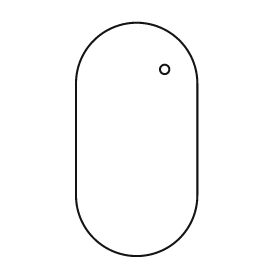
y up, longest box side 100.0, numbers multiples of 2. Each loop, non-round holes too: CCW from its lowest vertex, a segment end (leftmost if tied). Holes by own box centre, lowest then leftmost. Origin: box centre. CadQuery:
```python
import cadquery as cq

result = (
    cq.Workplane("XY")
    .moveTo(-26.0, -24.0)
    .threePointArc((0.0, -50.0), (26.0, -24.0))
    .lineTo(26.0, 24.0)
    .threePointArc((0.0, 50.0), (-26.0, 24.0))
    .close()
    .moveTo(12.0, 30.0)
    .circle(2.0)
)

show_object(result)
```